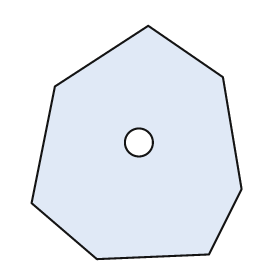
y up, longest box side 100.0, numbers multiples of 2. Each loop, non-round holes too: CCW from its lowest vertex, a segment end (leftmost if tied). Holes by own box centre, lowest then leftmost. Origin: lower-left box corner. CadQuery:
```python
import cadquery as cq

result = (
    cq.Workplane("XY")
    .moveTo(28.0, 0.0)
    .lineTo(76.0, 2.0)
    .lineTo(90.0, 30.0)
    .lineTo(82.0, 78.0)
    .lineTo(50.0, 100.0)
    .lineTo(10.0, 74.0)
    .lineTo(0.0, 24.0)
    .close()
    .moveTo(46.0, 50.0)
    .circle(6.0)
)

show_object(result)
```